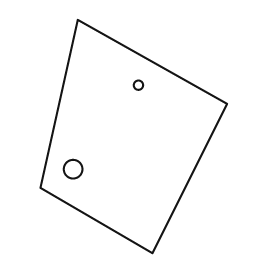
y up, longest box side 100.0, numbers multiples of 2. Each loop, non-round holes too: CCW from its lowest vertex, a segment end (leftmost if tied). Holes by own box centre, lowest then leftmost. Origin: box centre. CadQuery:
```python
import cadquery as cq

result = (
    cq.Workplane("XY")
    .moveTo(8.0, -50.0)
    .lineTo(40.0, 14.0)
    .lineTo(-24.0, 50.0)
    .lineTo(-40.0, -22.0)
    .close()
    .moveTo(-26.0, -14.0)
    .circle(4.0)
    .moveTo(2.0, 22.0)
    .circle(2.0)
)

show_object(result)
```